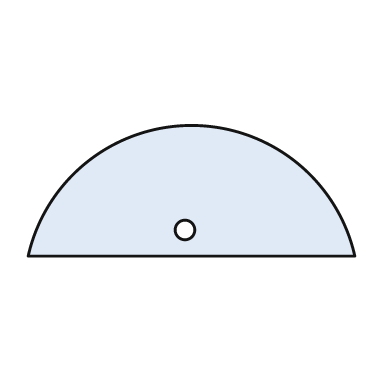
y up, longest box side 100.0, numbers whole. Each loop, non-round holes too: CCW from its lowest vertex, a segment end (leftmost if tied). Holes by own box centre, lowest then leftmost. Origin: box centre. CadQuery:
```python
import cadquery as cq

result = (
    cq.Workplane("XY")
    .moveTo(-50.0, -20.0)
    .lineTo(50.0, -20.0)
    .threePointArc((0.0, 20.0), (-50.0, -20.0))
    .close()
    .moveTo(-2.0, -12.0)
    .circle(3.0)
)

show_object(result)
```